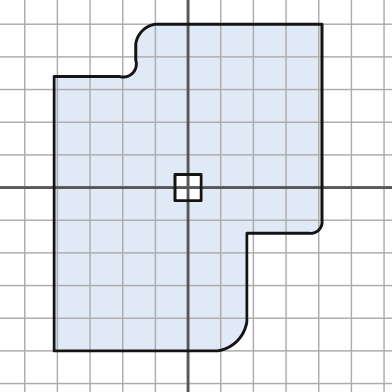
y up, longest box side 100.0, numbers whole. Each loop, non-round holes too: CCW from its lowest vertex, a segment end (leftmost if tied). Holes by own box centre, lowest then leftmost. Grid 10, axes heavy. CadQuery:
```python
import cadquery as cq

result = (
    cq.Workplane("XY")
    .moveTo(-41.0, -50.0)
    .lineTo(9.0, -50.0)
    .threePointArc((15.0, -47.0), (18.0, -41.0))
    .lineTo(18.0, -14.0)
    .lineTo(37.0, -14.0)
    .threePointArc((40.0, -13.0), (41.0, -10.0))
    .lineTo(41.0, 50.0)
    .lineTo(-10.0, 50.0)
    .threePointArc((-14.0, 48.0), (-16.0, 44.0))
    .lineTo(-16.0, 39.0)
    .threePointArc((-17.0, 35.0), (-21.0, 34.0))
    .lineTo(-41.0, 34.0)
    .close()
    .moveTo(-4.0, -4.0)
    .lineTo(4.0, -4.0)
    .lineTo(4.0, 4.0)
    .lineTo(-4.0, 4.0)
    .close()
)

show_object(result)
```